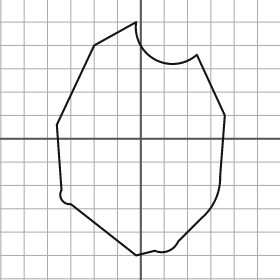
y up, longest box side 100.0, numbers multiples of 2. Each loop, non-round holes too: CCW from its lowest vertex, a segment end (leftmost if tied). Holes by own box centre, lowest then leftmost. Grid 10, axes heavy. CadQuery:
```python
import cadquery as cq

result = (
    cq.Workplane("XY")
    .moveTo(-2.0, -50.0)
    .lineTo(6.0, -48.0)
    .threePointArc((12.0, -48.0), (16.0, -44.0))
    .lineTo(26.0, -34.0)
    .threePointArc((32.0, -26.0), (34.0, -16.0))
    .lineTo(36.0, 10.0)
    .lineTo(24.0, 36.0)
    .threePointArc((6.0, 34.0), (-2.0, 50.0))
    .lineTo(-20.0, 40.0)
    .lineTo(-36.0, 6.0)
    .lineTo(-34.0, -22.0)
    .threePointArc((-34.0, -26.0), (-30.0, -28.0))
    .close()
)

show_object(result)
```